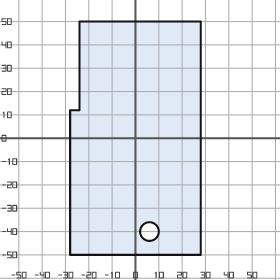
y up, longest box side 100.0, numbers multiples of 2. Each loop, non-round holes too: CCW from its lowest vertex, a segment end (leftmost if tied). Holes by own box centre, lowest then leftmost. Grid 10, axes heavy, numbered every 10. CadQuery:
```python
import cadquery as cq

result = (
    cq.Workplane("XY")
    .moveTo(-28.0, -50.0)
    .lineTo(28.0, -50.0)
    .lineTo(28.0, 50.0)
    .lineTo(-24.0, 50.0)
    .lineTo(-24.0, 12.0)
    .lineTo(-28.0, 12.0)
    .close()
    .moveTo(6.0, -40.0)
    .circle(4.0)
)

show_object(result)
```